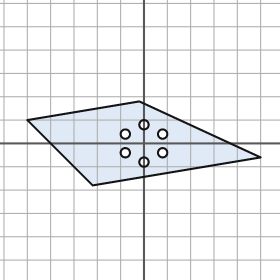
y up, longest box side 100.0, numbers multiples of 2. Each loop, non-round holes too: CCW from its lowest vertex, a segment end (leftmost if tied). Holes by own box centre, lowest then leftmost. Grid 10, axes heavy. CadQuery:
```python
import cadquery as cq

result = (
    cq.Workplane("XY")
    .moveTo(-22.0, -18.0)
    .lineTo(50.0, -6.0)
    .lineTo(-2.0, 18.0)
    .lineTo(-50.0, 10.0)
    .close()
    .moveTo(0.0, -8.0)
    .circle(2.0)
    .moveTo(-8.0, -4.0)
    .circle(2.0)
    .moveTo(8.0, -4.0)
    .circle(2.0)
    .moveTo(-8.0, 4.0)
    .circle(2.0)
    .moveTo(8.0, 4.0)
    .circle(2.0)
    .moveTo(0.0, 8.0)
    .circle(2.0)
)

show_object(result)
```